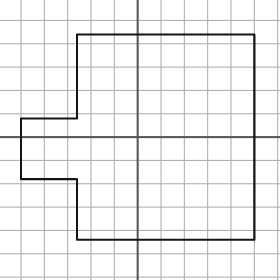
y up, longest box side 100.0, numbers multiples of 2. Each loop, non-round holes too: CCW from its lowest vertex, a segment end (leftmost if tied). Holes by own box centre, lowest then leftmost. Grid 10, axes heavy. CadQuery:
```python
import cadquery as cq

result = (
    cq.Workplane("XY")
    .moveTo(-26.0, -44.0)
    .lineTo(50.0, -44.0)
    .lineTo(50.0, 44.0)
    .lineTo(-26.0, 44.0)
    .lineTo(-26.0, 8.0)
    .lineTo(-50.0, 8.0)
    .lineTo(-50.0, -18.0)
    .lineTo(-26.0, -18.0)
    .close()
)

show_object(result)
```